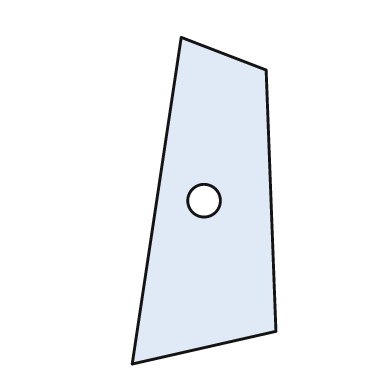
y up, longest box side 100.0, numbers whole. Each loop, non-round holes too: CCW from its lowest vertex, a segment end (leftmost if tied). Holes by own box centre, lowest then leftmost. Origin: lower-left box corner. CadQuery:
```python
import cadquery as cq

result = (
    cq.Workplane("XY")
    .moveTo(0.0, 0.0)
    .lineTo(44.0, 10.0)
    .lineTo(41.0, 90.0)
    .lineTo(15.0, 100.0)
    .close()
    .moveTo(22.0, 50.0)
    .circle(5.0)
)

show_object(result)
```